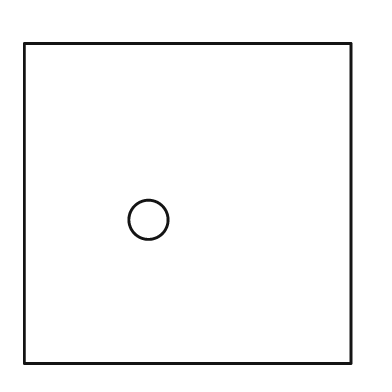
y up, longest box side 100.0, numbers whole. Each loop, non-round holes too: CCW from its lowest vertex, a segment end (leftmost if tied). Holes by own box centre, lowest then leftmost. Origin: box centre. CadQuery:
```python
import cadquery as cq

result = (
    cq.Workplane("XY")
    .moveTo(-50.0, -49.0)
    .lineTo(50.0, -49.0)
    .lineTo(50.0, 49.0)
    .lineTo(-50.0, 49.0)
    .close()
    .moveTo(-12.0, -5.0)
    .circle(6.0)
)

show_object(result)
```